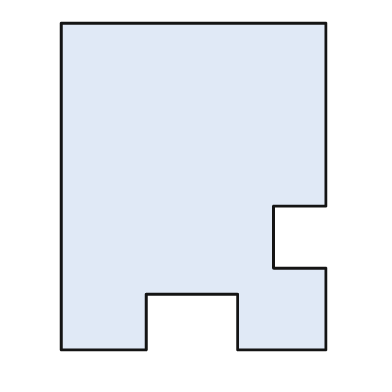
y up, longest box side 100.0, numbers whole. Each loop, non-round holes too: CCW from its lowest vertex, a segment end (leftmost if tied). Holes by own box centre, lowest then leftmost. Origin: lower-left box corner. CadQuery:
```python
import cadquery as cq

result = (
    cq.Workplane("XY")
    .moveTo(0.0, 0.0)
    .lineTo(26.0, 0.0)
    .lineTo(26.0, 17.0)
    .lineTo(54.0, 17.0)
    .lineTo(54.0, 0.0)
    .lineTo(81.0, 0.0)
    .lineTo(81.0, 25.0)
    .lineTo(65.0, 25.0)
    .lineTo(65.0, 44.0)
    .lineTo(81.0, 44.0)
    .lineTo(81.0, 100.0)
    .lineTo(0.0, 100.0)
    .close()
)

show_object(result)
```